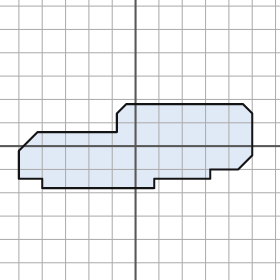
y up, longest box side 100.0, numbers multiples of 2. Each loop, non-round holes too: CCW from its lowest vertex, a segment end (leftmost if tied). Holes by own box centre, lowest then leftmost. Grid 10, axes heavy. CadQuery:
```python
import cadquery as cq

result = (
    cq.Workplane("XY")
    .moveTo(-40.0, -18.0)
    .lineTo(8.0, -18.0)
    .lineTo(8.0, -14.0)
    .lineTo(32.0, -14.0)
    .lineTo(32.0, -10.0)
    .lineTo(44.0, -10.0)
    .lineTo(50.0, -4.0)
    .lineTo(50.0, 14.0)
    .lineTo(46.0, 18.0)
    .lineTo(-4.0, 18.0)
    .lineTo(-8.0, 14.0)
    .lineTo(-8.0, 6.0)
    .lineTo(-42.0, 6.0)
    .lineTo(-50.0, -2.0)
    .lineTo(-50.0, -14.0)
    .lineTo(-40.0, -14.0)
    .close()
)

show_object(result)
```